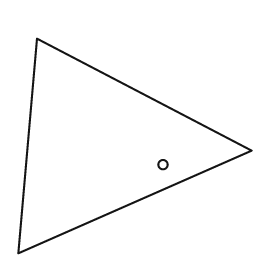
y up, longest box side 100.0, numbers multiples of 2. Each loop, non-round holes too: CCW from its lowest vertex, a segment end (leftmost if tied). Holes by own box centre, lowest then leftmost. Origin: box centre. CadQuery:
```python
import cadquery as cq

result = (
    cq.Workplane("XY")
    .moveTo(-50.0, -46.0)
    .lineTo(50.0, -2.0)
    .lineTo(-42.0, 46.0)
    .close()
    .moveTo(12.0, -8.0)
    .circle(2.0)
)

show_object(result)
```